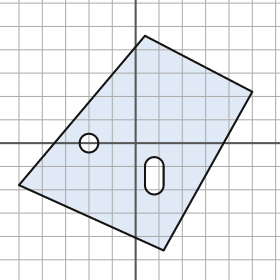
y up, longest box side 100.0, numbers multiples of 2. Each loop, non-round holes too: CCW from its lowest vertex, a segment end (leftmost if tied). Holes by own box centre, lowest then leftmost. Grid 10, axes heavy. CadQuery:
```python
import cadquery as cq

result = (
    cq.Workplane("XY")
    .moveTo(12.0, -46.0)
    .lineTo(50.0, 22.0)
    .lineTo(4.0, 46.0)
    .lineTo(-50.0, -18.0)
    .close()
    .moveTo(4.0, -18.0)
    .threePointArc((8.0, -22.0), (12.0, -18.0))
    .lineTo(12.0, -10.0)
    .threePointArc((8.0, -6.0), (4.0, -10.0))
    .close()
    .moveTo(-20.0, 0.0)
    .circle(4.0)
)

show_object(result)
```